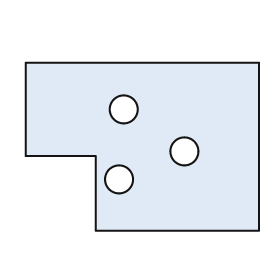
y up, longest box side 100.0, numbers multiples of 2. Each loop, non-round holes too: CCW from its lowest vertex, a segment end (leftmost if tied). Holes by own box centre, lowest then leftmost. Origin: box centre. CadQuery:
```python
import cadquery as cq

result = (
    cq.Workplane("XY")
    .moveTo(-20.0, -36.0)
    .lineTo(50.0, -36.0)
    .lineTo(50.0, 36.0)
    .lineTo(-50.0, 36.0)
    .lineTo(-50.0, -4.0)
    .lineTo(-20.0, -4.0)
    .close()
    .moveTo(-10.0, -14.0)
    .circle(6.0)
    .moveTo(18.0, -2.0)
    .circle(6.0)
    .moveTo(-8.0, 16.0)
    .circle(6.0)
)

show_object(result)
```